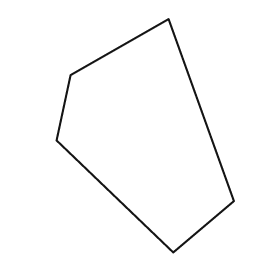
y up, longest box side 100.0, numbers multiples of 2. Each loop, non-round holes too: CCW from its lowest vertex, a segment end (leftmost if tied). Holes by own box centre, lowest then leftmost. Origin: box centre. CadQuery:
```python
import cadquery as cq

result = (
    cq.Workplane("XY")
    .moveTo(12.0, -50.0)
    .lineTo(38.0, -28.0)
    .lineTo(10.0, 50.0)
    .lineTo(-32.0, 26.0)
    .lineTo(-38.0, -2.0)
    .close()
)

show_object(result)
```